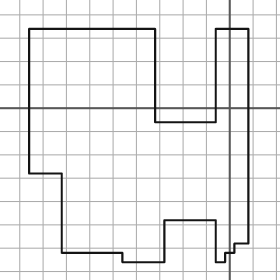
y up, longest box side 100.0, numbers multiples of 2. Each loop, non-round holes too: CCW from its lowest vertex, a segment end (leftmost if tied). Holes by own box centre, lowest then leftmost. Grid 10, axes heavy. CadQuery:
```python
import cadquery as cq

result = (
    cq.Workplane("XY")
    .moveTo(-46.0, -66.0)
    .lineTo(-28.0, -66.0)
    .lineTo(-28.0, -48.0)
    .lineTo(-6.0, -48.0)
    .lineTo(-6.0, -66.0)
    .lineTo(-2.0, -66.0)
    .lineTo(-2.0, -62.0)
    .lineTo(2.0, -62.0)
    .lineTo(2.0, -58.0)
    .lineTo(8.0, -58.0)
    .lineTo(8.0, 34.0)
    .lineTo(-6.0, 34.0)
    .lineTo(-6.0, -6.0)
    .lineTo(-32.0, -6.0)
    .lineTo(-32.0, 34.0)
    .lineTo(-86.0, 34.0)
    .lineTo(-86.0, -28.0)
    .lineTo(-72.0, -28.0)
    .lineTo(-72.0, -62.0)
    .lineTo(-46.0, -62.0)
    .close()
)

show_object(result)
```